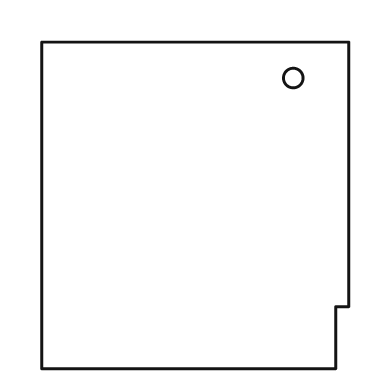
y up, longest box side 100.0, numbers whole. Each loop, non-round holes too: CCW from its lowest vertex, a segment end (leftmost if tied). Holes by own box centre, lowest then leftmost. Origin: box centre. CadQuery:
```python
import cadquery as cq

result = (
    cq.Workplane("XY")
    .moveTo(-47.0, -50.0)
    .lineTo(43.0, -50.0)
    .lineTo(43.0, -31.0)
    .lineTo(47.0, -31.0)
    .lineTo(47.0, 50.0)
    .lineTo(-47.0, 50.0)
    .close()
    .moveTo(30.0, 39.0)
    .circle(3.0)
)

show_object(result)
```